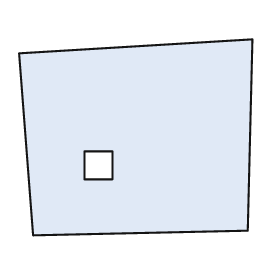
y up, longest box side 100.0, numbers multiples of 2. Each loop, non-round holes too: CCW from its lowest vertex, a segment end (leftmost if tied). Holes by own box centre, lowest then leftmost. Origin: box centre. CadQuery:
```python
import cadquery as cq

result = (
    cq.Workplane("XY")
    .moveTo(-44.0, -42.0)
    .lineTo(48.0, -40.0)
    .lineTo(50.0, 42.0)
    .lineTo(-50.0, 36.0)
    .close()
    .moveTo(-22.0, -18.0)
    .lineTo(-10.0, -18.0)
    .lineTo(-10.0, -6.0)
    .lineTo(-22.0, -6.0)
    .close()
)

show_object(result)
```